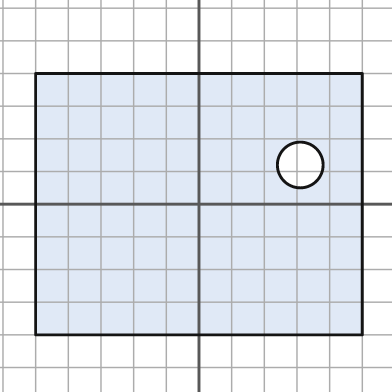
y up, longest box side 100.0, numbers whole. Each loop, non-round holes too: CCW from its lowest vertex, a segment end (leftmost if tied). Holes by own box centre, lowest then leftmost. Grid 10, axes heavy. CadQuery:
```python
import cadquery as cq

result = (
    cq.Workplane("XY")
    .moveTo(-50.0, -40.0)
    .lineTo(50.0, -40.0)
    .lineTo(50.0, 40.0)
    .lineTo(-50.0, 40.0)
    .close()
    .moveTo(31.0, 12.0)
    .circle(7.0)
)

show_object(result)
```